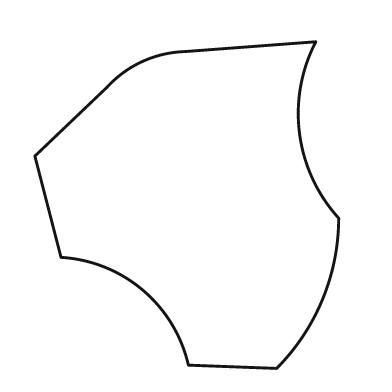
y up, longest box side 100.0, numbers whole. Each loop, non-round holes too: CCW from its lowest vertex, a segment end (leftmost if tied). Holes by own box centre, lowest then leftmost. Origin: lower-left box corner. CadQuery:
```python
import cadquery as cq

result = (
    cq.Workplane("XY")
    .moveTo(74.0, 0.0)
    .threePointArc((88.0, 21.0), (93.0, 46.0))
    .threePointArc((81.0, 72.0), (86.0, 100.0))
    .lineTo(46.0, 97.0)
    .threePointArc((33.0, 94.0), (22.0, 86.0))
    .lineTo(0.0, 65.0)
    .lineTo(8.0, 34.0)
    .threePointArc((33.0, 24.0), (47.0, 1.0))
    .close()
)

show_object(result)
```